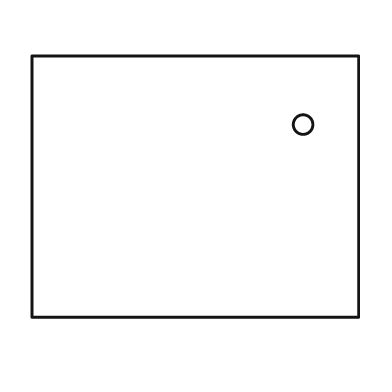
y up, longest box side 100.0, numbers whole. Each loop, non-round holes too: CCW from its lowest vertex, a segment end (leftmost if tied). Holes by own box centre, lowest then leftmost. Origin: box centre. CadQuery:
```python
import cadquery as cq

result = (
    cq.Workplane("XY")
    .moveTo(-50.0, -40.0)
    .lineTo(50.0, -40.0)
    .lineTo(50.0, 40.0)
    .lineTo(-50.0, 40.0)
    .close()
    .moveTo(33.0, 19.0)
    .circle(3.0)
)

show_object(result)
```